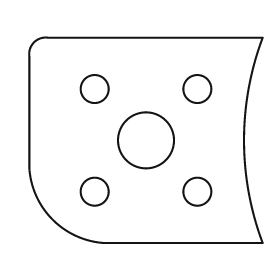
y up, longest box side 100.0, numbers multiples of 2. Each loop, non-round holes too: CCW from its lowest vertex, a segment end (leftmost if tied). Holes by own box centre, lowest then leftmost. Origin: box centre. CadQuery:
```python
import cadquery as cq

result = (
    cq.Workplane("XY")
    .moveTo(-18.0, -44.0)
    .lineTo(50.0, -44.0)
    .threePointArc((42.0, 0.0), (50.0, 44.0))
    .lineTo(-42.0, 44.0)
    .threePointArc((-48.0, 42.0), (-50.0, 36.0))
    .lineTo(-50.0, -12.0)
    .threePointArc((-40.0, -34.0), (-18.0, -44.0))
    .close()
    .moveTo(-22.0, -22.0)
    .circle(6.0)
    .moveTo(22.0, -22.0)
    .circle(6.0)
    .moveTo(0.0, 0.0)
    .circle(12.0)
    .moveTo(-22.0, 22.0)
    .circle(6.0)
    .moveTo(22.0, 22.0)
    .circle(6.0)
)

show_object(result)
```